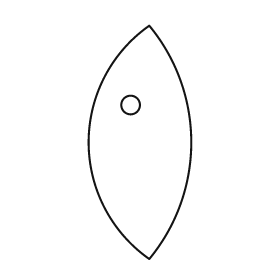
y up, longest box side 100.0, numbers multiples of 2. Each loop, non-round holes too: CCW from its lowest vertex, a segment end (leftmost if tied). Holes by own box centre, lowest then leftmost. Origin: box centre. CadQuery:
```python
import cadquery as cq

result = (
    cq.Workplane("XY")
    .moveTo(4.0, -50.0)
    .threePointArc((22.0, 0.0), (4.0, 50.0))
    .threePointArc((-22.0, 0.0), (4.0, -50.0))
    .close()
    .moveTo(-4.0, 16.0)
    .circle(4.0)
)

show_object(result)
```